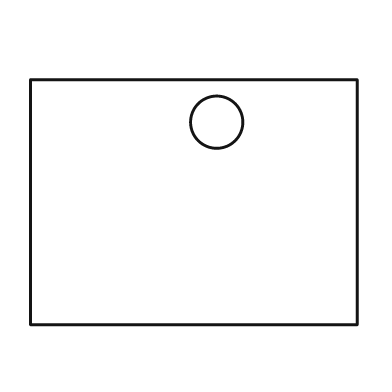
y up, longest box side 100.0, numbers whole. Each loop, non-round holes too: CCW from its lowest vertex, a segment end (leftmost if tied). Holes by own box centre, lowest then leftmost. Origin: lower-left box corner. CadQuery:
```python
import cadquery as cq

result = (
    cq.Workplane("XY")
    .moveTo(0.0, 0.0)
    .lineTo(100.0, 0.0)
    .lineTo(100.0, 75.0)
    .lineTo(0.0, 75.0)
    .close()
    .moveTo(57.0, 62.0)
    .circle(8.0)
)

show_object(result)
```